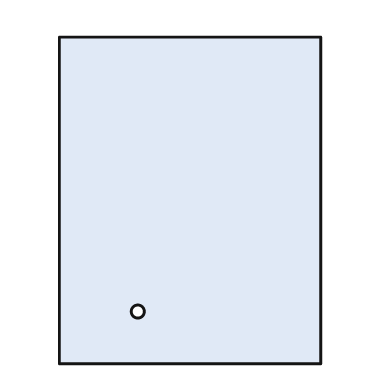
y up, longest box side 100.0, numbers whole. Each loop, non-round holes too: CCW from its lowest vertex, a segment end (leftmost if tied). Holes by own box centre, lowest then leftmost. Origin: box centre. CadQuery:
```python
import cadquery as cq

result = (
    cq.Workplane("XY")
    .moveTo(-40.0, -50.0)
    .lineTo(40.0, -50.0)
    .lineTo(40.0, 50.0)
    .lineTo(-40.0, 50.0)
    .close()
    .moveTo(-16.0, -34.0)
    .circle(2.0)
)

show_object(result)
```